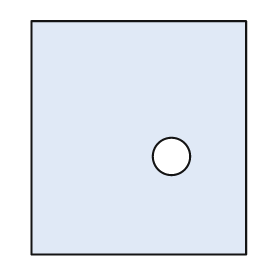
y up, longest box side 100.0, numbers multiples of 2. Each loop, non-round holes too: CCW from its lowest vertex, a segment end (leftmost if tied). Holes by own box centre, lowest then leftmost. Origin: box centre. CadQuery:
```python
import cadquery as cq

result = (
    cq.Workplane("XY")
    .moveTo(-46.0, -50.0)
    .lineTo(46.0, -50.0)
    .lineTo(46.0, 50.0)
    .lineTo(-46.0, 50.0)
    .close()
    .moveTo(14.0, -8.0)
    .circle(8.0)
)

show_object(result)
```